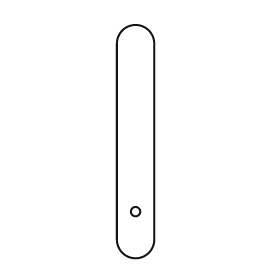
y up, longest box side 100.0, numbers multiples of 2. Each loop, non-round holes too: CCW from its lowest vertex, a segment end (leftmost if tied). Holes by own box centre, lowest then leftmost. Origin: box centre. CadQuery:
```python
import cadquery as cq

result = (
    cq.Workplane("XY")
    .moveTo(-8.0, -42.0)
    .threePointArc((0.0, -50.0), (8.0, -42.0))
    .lineTo(8.0, 42.0)
    .threePointArc((0.0, 50.0), (-8.0, 42.0))
    .close()
    .moveTo(0.0, -30.0)
    .circle(2.0)
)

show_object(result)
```